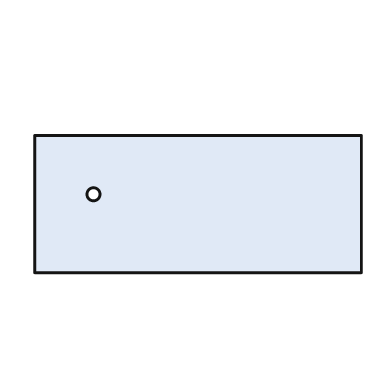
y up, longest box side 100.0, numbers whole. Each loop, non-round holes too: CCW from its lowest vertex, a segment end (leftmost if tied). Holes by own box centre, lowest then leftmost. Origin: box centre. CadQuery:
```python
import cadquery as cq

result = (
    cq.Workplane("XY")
    .moveTo(-50.0, -21.0)
    .lineTo(50.0, -21.0)
    .lineTo(50.0, 21.0)
    .lineTo(-50.0, 21.0)
    .close()
    .moveTo(-32.0, 3.0)
    .circle(2.0)
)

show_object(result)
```